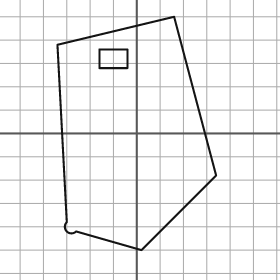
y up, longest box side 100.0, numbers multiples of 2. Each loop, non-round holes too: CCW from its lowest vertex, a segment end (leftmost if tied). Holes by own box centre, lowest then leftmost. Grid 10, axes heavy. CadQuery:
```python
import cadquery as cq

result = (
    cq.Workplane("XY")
    .moveTo(2.0, -50.0)
    .lineTo(34.0, -18.0)
    .lineTo(16.0, 50.0)
    .lineTo(-34.0, 38.0)
    .lineTo(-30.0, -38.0)
    .threePointArc((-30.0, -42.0), (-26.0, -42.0))
    .close()
    .moveTo(-16.0, 28.0)
    .lineTo(-4.0, 28.0)
    .lineTo(-4.0, 36.0)
    .lineTo(-16.0, 36.0)
    .close()
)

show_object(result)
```